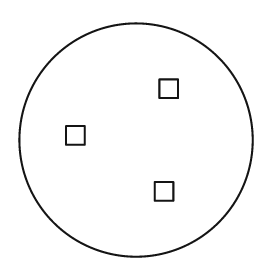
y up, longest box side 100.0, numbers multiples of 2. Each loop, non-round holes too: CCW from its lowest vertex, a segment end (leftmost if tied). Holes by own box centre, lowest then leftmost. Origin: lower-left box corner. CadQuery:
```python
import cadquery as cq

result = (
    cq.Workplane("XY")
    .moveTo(50.0, 50.0)
    .circle(50.0)
    .moveTo(58.0, 24.0)
    .lineTo(66.0, 24.0)
    .lineTo(66.0, 32.0)
    .lineTo(58.0, 32.0)
    .close()
    .moveTo(20.0, 48.0)
    .lineTo(28.0, 48.0)
    .lineTo(28.0, 56.0)
    .lineTo(20.0, 56.0)
    .close()
    .moveTo(60.0, 68.0)
    .lineTo(68.0, 68.0)
    .lineTo(68.0, 76.0)
    .lineTo(60.0, 76.0)
    .close()
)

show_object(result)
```